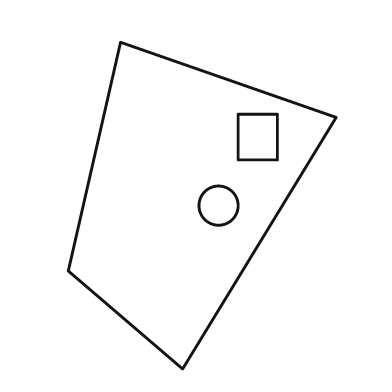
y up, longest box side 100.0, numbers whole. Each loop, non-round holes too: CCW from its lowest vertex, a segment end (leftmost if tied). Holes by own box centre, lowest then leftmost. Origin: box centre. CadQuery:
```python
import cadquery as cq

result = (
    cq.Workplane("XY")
    .moveTo(-6.0, -50.0)
    .lineTo(41.0, 27.0)
    .lineTo(-25.0, 50.0)
    .lineTo(-41.0, -20.0)
    .close()
    .moveTo(5.0, 0.0)
    .circle(6.0)
    .moveTo(11.0, 14.0)
    .lineTo(23.0, 14.0)
    .lineTo(23.0, 28.0)
    .lineTo(11.0, 28.0)
    .close()
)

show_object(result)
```